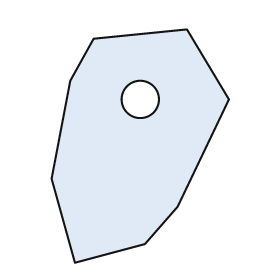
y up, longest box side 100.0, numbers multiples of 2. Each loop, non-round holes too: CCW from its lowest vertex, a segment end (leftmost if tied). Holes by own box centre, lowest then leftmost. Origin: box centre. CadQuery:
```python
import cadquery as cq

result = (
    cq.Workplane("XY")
    .moveTo(-28.0, -50.0)
    .lineTo(2.0, -42.0)
    .lineTo(16.0, -26.0)
    .lineTo(38.0, 20.0)
    .lineTo(20.0, 50.0)
    .lineTo(-20.0, 46.0)
    .lineTo(-30.0, 28.0)
    .lineTo(-38.0, -14.0)
    .close()
    .moveTo(0.0, 20.0)
    .circle(8.0)
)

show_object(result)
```